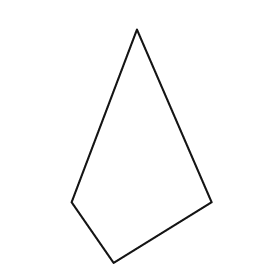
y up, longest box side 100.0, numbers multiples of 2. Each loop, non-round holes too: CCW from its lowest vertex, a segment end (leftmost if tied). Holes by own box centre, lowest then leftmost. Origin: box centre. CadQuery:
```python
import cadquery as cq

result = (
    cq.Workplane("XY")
    .moveTo(-12.0, -50.0)
    .lineTo(30.0, -24.0)
    .lineTo(-2.0, 50.0)
    .lineTo(-30.0, -24.0)
    .close()
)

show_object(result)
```